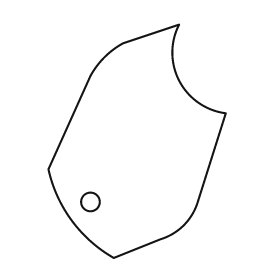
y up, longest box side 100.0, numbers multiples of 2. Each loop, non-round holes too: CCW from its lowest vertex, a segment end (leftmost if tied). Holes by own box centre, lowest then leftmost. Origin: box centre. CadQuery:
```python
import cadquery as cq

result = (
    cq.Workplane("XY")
    .moveTo(-10.0, -50.0)
    .lineTo(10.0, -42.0)
    .threePointArc((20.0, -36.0), (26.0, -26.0))
    .lineTo(38.0, 12.0)
    .threePointArc((18.0, 26.0), (18.0, 50.0))
    .lineTo(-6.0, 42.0)
    .threePointArc((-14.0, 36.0), (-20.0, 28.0))
    .lineTo(-38.0, -12.0)
    .threePointArc((-28.0, -34.0), (-10.0, -50.0))
    .close()
    .moveTo(-20.0, -26.0)
    .circle(4.0)
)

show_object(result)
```